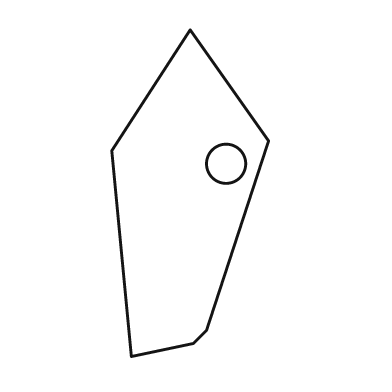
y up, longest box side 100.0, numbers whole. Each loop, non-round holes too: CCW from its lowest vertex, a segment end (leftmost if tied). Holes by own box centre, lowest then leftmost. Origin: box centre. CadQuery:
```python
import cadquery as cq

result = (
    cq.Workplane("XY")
    .moveTo(-18.0, -50.0)
    .lineTo(1.0, -46.0)
    .lineTo(5.0, -42.0)
    .lineTo(24.0, 16.0)
    .lineTo(0.0, 50.0)
    .lineTo(-24.0, 13.0)
    .close()
    .moveTo(11.0, 9.0)
    .circle(6.0)
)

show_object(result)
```